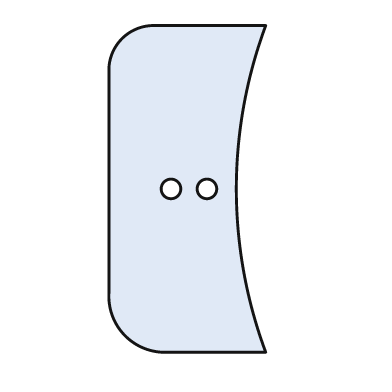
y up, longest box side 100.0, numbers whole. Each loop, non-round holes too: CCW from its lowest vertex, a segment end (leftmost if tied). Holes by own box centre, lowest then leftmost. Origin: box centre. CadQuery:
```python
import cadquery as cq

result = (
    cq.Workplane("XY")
    .moveTo(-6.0, -50.0)
    .lineTo(24.0, -50.0)
    .threePointArc((15.0, 0.0), (24.0, 50.0))
    .lineTo(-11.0, 50.0)
    .threePointArc((-20.0, 46.0), (-24.0, 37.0))
    .lineTo(-24.0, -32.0)
    .threePointArc((-19.0, -45.0), (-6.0, -50.0))
    .close()
    .moveTo(-5.0, 0.0)
    .circle(3.0)
    .moveTo(6.0, 0.0)
    .circle(3.0)
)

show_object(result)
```